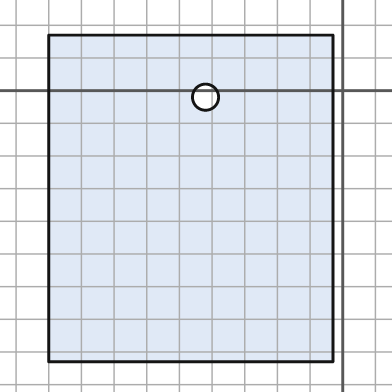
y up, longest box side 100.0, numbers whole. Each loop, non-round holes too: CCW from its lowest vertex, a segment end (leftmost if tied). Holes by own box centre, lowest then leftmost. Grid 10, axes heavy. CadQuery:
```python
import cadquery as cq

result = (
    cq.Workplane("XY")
    .moveTo(-90.0, -83.0)
    .lineTo(-3.0, -83.0)
    .lineTo(-3.0, 17.0)
    .lineTo(-90.0, 17.0)
    .close()
    .moveTo(-42.0, -2.0)
    .circle(4.0)
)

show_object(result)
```